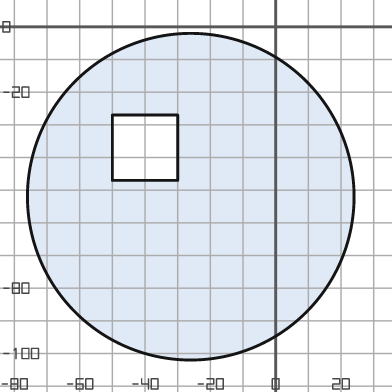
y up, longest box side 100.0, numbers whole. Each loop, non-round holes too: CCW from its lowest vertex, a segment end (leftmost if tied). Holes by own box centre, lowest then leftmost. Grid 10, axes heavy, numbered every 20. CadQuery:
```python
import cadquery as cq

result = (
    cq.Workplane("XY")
    .moveTo(-26.0, -52.0)
    .circle(50.0)
    .moveTo(-50.0, -47.0)
    .lineTo(-30.0, -47.0)
    .lineTo(-30.0, -27.0)
    .lineTo(-50.0, -27.0)
    .close()
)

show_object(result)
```